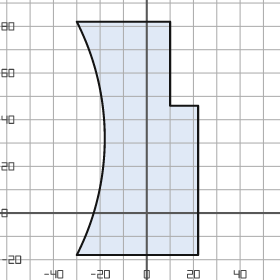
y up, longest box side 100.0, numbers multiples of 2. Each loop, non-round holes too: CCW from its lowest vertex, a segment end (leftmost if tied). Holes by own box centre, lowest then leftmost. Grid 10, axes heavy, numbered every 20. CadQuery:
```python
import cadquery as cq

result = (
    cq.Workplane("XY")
    .moveTo(-30.0, -18.0)
    .lineTo(22.0, -18.0)
    .lineTo(22.0, 46.0)
    .lineTo(10.0, 46.0)
    .lineTo(10.0, 82.0)
    .lineTo(-30.0, 82.0)
    .threePointArc((-18.0, 32.0), (-30.0, -18.0))
    .close()
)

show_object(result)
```